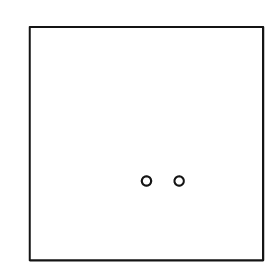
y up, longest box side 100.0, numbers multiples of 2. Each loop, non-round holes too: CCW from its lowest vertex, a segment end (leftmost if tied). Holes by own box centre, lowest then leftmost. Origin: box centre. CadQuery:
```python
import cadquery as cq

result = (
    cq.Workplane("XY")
    .moveTo(-50.0, -50.0)
    .lineTo(50.0, -50.0)
    .lineTo(50.0, 50.0)
    .lineTo(-50.0, 50.0)
    .close()
    .moveTo(0.0, -16.0)
    .circle(2.0)
    .moveTo(14.0, -16.0)
    .circle(2.0)
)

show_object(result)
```